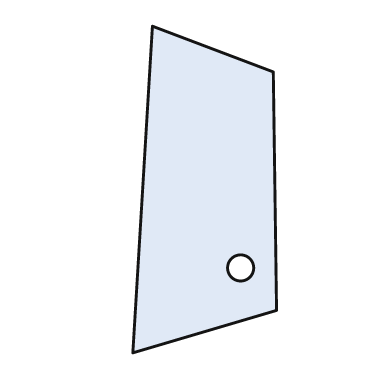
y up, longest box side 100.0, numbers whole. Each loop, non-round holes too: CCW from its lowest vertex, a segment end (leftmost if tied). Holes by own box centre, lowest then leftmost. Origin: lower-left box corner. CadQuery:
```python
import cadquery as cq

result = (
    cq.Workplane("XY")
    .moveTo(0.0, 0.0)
    .lineTo(44.0, 13.0)
    .lineTo(43.0, 86.0)
    .lineTo(6.0, 100.0)
    .close()
    .moveTo(33.0, 26.0)
    .circle(4.0)
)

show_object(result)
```